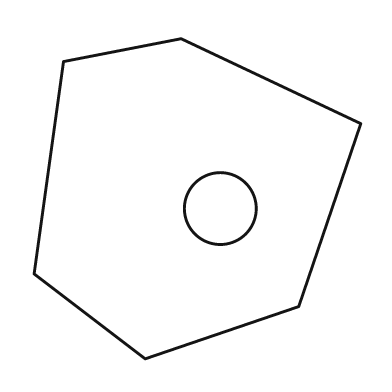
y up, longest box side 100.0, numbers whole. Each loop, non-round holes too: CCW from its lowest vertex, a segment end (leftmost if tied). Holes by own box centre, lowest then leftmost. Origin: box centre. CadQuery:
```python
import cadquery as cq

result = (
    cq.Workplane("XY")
    .moveTo(-16.0, -49.0)
    .lineTo(31.0, -33.0)
    .lineTo(50.0, 23.0)
    .lineTo(-5.0, 49.0)
    .lineTo(-41.0, 42.0)
    .lineTo(-50.0, -23.0)
    .close()
    .moveTo(7.0, -3.0)
    .circle(11.0)
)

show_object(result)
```